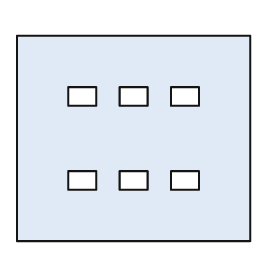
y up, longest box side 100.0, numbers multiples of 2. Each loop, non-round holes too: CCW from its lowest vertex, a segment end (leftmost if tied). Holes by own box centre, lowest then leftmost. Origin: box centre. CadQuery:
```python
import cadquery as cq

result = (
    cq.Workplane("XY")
    .moveTo(-50.0, -44.0)
    .lineTo(50.0, -44.0)
    .lineTo(50.0, 44.0)
    .lineTo(-50.0, 44.0)
    .close()
    .moveTo(-28.0, -22.0)
    .lineTo(-16.0, -22.0)
    .lineTo(-16.0, -14.0)
    .lineTo(-28.0, -14.0)
    .close()
    .moveTo(-6.0, -22.0)
    .lineTo(6.0, -22.0)
    .lineTo(6.0, -14.0)
    .lineTo(-6.0, -14.0)
    .close()
    .moveTo(16.0, -22.0)
    .lineTo(28.0, -22.0)
    .lineTo(28.0, -14.0)
    .lineTo(16.0, -14.0)
    .close()
    .moveTo(-28.0, 14.0)
    .lineTo(-16.0, 14.0)
    .lineTo(-16.0, 22.0)
    .lineTo(-28.0, 22.0)
    .close()
    .moveTo(-6.0, 14.0)
    .lineTo(6.0, 14.0)
    .lineTo(6.0, 22.0)
    .lineTo(-6.0, 22.0)
    .close()
    .moveTo(16.0, 14.0)
    .lineTo(28.0, 14.0)
    .lineTo(28.0, 22.0)
    .lineTo(16.0, 22.0)
    .close()
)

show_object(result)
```